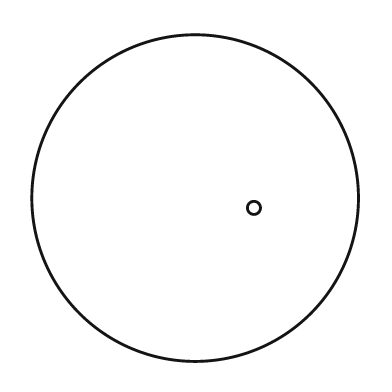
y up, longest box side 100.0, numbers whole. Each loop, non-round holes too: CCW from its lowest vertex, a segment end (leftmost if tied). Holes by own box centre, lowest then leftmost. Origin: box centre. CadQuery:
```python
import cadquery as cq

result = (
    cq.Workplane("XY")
    .moveTo(0.0, 0.0)
    .circle(50.0)
    .moveTo(18.0, -3.0)
    .circle(2.0)
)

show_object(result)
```